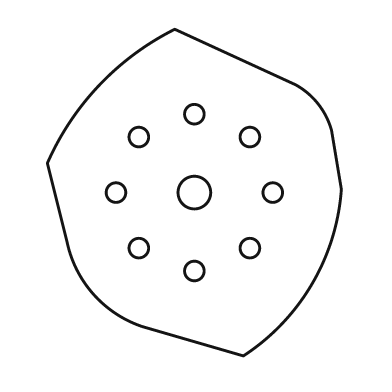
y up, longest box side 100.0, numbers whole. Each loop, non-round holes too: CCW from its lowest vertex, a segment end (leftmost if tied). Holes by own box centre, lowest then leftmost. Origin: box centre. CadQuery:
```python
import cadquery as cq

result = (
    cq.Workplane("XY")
    .moveTo(15.0, -50.0)
    .threePointArc((36.0, -28.0), (45.0, 1.0))
    .lineTo(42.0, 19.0)
    .threePointArc((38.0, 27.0), (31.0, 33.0))
    .lineTo(-6.0, 50.0)
    .threePointArc((-29.0, 33.0), (-45.0, 9.0))
    .lineTo(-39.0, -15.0)
    .threePointArc((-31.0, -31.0), (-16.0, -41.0))
    .close()
    .moveTo(0.0, -24.0)
    .circle(3.0)
    .moveTo(-17.0, -17.0)
    .circle(3.0)
    .moveTo(17.0, -17.0)
    .circle(3.0)
    .moveTo(-24.0, 0.0)
    .circle(3.0)
    .moveTo(0.0, 0.0)
    .circle(5.0)
    .moveTo(24.0, 0.0)
    .circle(3.0)
    .moveTo(-17.0, 17.0)
    .circle(3.0)
    .moveTo(17.0, 17.0)
    .circle(3.0)
    .moveTo(0.0, 24.0)
    .circle(3.0)
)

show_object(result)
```